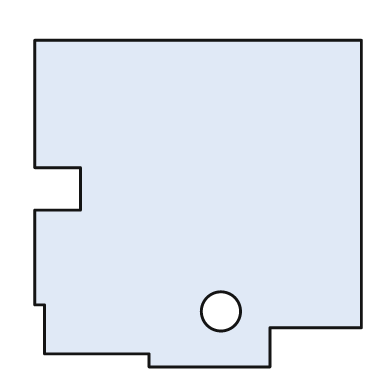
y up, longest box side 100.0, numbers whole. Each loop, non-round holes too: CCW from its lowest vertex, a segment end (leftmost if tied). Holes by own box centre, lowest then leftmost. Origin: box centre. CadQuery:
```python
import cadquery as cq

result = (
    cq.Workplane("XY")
    .moveTo(-15.0, -50.0)
    .lineTo(22.0, -50.0)
    .lineTo(22.0, -38.0)
    .lineTo(50.0, -38.0)
    .lineTo(50.0, 50.0)
    .lineTo(-50.0, 50.0)
    .lineTo(-50.0, 11.0)
    .lineTo(-36.0, 11.0)
    .lineTo(-36.0, -2.0)
    .lineTo(-50.0, -2.0)
    .lineTo(-50.0, -31.0)
    .lineTo(-47.0, -31.0)
    .lineTo(-47.0, -46.0)
    .lineTo(-15.0, -46.0)
    .close()
    .moveTo(7.0, -33.0)
    .circle(6.0)
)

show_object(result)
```